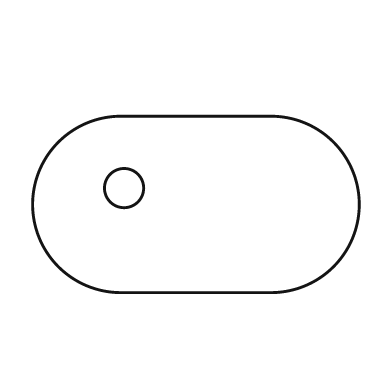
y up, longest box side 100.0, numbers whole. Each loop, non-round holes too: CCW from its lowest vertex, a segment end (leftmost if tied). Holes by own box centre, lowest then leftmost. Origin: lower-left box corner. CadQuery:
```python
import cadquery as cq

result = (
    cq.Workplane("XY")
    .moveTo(27.0, 0.0)
    .lineTo(73.0, 0.0)
    .threePointArc((100.0, 27.0), (73.0, 54.0))
    .lineTo(27.0, 54.0)
    .threePointArc((0.0, 27.0), (27.0, 0.0))
    .close()
    .moveTo(28.0, 32.0)
    .circle(6.0)
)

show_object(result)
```